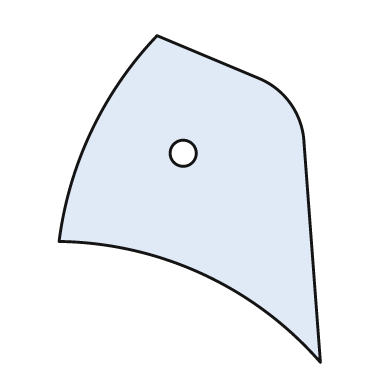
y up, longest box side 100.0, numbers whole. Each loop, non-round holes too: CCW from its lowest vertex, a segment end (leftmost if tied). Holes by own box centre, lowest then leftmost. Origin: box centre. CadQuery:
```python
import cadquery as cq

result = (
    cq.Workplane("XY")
    .moveTo(40.0, -50.0)
    .lineTo(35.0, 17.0)
    .threePointArc((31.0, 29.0), (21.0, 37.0))
    .lineTo(-10.0, 50.0)
    .threePointArc((-30.0, 21.0), (-40.0, -13.0))
    .threePointArc((4.0, -23.0), (40.0, -50.0))
    .close()
    .moveTo(-2.0, 14.0)
    .circle(4.0)
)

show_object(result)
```